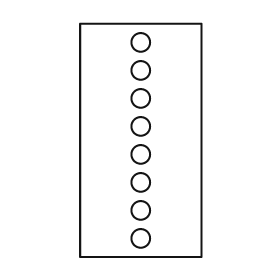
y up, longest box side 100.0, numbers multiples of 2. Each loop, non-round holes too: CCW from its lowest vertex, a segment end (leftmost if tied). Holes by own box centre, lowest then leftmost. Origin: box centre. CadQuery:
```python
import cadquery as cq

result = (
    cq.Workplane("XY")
    .moveTo(-26.0, -50.0)
    .lineTo(26.0, -50.0)
    .lineTo(26.0, 50.0)
    .lineTo(-26.0, 50.0)
    .close()
    .moveTo(0.0, -42.0)
    .circle(4.0)
    .moveTo(0.0, -30.0)
    .circle(4.0)
    .moveTo(0.0, -18.0)
    .circle(4.0)
    .moveTo(0.0, -6.0)
    .circle(4.0)
    .moveTo(0.0, 6.0)
    .circle(4.0)
    .moveTo(0.0, 18.0)
    .circle(4.0)
    .moveTo(0.0, 30.0)
    .circle(4.0)
    .moveTo(0.0, 42.0)
    .circle(4.0)
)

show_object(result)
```